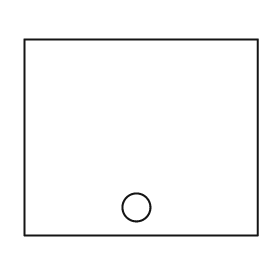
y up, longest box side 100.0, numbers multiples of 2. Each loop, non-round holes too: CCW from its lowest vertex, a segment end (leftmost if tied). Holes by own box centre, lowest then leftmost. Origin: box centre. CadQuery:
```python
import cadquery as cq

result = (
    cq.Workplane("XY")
    .moveTo(-50.0, -42.0)
    .lineTo(50.0, -42.0)
    .lineTo(50.0, 42.0)
    .lineTo(-50.0, 42.0)
    .close()
    .moveTo(-2.0, -30.0)
    .circle(6.0)
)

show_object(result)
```